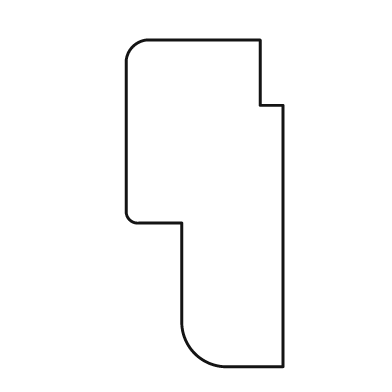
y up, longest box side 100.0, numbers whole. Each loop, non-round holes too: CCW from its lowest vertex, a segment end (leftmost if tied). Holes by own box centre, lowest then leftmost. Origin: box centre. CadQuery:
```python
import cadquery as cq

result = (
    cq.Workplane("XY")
    .moveTo(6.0, -50.0)
    .lineTo(24.0, -50.0)
    .lineTo(24.0, 30.0)
    .lineTo(17.0, 30.0)
    .lineTo(17.0, 50.0)
    .lineTo(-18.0, 50.0)
    .threePointArc((-22.0, 48.0), (-24.0, 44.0))
    .lineTo(-24.0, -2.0)
    .threePointArc((-23.0, -5.0), (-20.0, -6.0))
    .lineTo(-7.0, -6.0)
    .lineTo(-7.0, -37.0)
    .threePointArc((-3.0, -46.0), (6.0, -50.0))
    .close()
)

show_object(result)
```